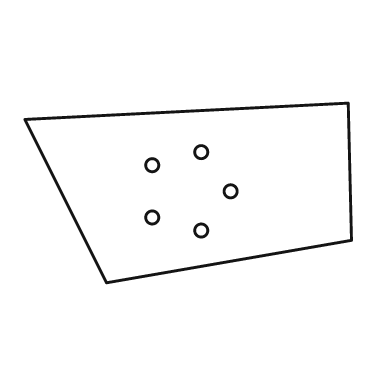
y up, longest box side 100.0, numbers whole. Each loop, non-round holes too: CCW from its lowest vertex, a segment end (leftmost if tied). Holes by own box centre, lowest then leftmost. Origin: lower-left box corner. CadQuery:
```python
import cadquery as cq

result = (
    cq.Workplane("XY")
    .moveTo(25.0, 0.0)
    .lineTo(100.0, 13.0)
    .lineTo(99.0, 55.0)
    .lineTo(0.0, 50.0)
    .close()
    .moveTo(54.0, 16.0)
    .circle(2.0)
    .moveTo(39.0, 20.0)
    .circle(2.0)
    .moveTo(63.0, 28.0)
    .circle(2.0)
    .moveTo(39.0, 36.0)
    .circle(2.0)
    .moveTo(54.0, 40.0)
    .circle(2.0)
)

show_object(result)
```